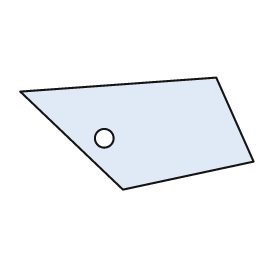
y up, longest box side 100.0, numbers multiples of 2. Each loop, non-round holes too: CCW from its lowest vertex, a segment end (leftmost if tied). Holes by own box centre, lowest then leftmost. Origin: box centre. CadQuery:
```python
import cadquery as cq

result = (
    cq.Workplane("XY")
    .moveTo(-6.0, -24.0)
    .lineTo(50.0, -12.0)
    .lineTo(34.0, 24.0)
    .lineTo(-50.0, 18.0)
    .close()
    .moveTo(-14.0, -2.0)
    .circle(4.0)
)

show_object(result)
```